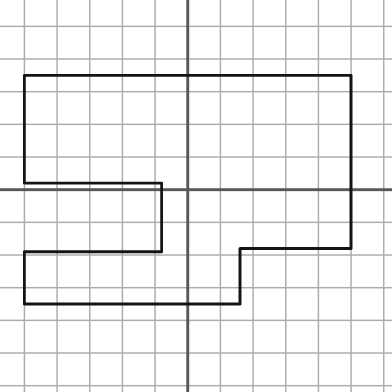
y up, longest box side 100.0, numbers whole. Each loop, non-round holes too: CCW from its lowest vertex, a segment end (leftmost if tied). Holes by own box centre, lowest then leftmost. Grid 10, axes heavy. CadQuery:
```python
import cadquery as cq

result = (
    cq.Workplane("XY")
    .moveTo(-50.0, -35.0)
    .lineTo(16.0, -35.0)
    .lineTo(16.0, -18.0)
    .lineTo(50.0, -18.0)
    .lineTo(50.0, 35.0)
    .lineTo(-50.0, 35.0)
    .lineTo(-50.0, 2.0)
    .lineTo(-8.0, 2.0)
    .lineTo(-8.0, -19.0)
    .lineTo(-50.0, -19.0)
    .close()
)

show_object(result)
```